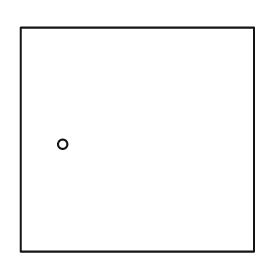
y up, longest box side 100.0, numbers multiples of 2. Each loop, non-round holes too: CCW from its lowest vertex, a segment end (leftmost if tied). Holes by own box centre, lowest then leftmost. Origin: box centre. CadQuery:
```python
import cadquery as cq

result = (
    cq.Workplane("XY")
    .moveTo(-50.0, -48.0)
    .lineTo(50.0, -48.0)
    .lineTo(50.0, 48.0)
    .lineTo(-50.0, 48.0)
    .close()
    .moveTo(-32.0, -2.0)
    .circle(2.0)
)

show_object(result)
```